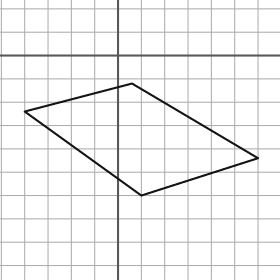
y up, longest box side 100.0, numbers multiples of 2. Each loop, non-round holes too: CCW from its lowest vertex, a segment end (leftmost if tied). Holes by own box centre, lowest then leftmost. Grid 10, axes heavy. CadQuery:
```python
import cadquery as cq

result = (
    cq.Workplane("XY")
    .moveTo(10.0, -60.0)
    .lineTo(60.0, -44.0)
    .lineTo(6.0, -12.0)
    .lineTo(-40.0, -24.0)
    .close()
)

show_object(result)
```